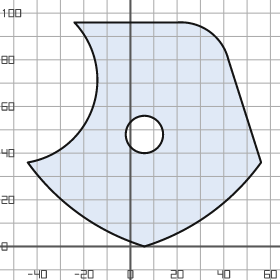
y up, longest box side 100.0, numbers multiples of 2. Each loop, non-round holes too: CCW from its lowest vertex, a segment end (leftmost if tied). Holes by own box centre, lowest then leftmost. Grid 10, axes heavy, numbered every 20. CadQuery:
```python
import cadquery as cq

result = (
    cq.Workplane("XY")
    .moveTo(6.0, 0.0)
    .threePointArc((34.0, 14.0), (56.0, 36.0))
    .lineTo(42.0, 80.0)
    .threePointArc((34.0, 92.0), (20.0, 96.0))
    .lineTo(-24.0, 96.0)
    .threePointArc((-16.0, 60.0), (-44.0, 36.0))
    .threePointArc((-22.0, 14.0), (6.0, 0.0))
    .close()
    .moveTo(6.0, 48.0)
    .circle(8.0)
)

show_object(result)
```